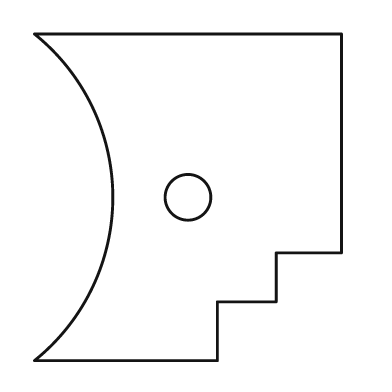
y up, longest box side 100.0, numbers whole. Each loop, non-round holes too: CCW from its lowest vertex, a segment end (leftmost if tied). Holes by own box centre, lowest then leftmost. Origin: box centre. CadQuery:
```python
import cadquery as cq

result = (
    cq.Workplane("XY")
    .moveTo(-47.0, -50.0)
    .lineTo(9.0, -50.0)
    .lineTo(9.0, -32.0)
    .lineTo(27.0, -32.0)
    .lineTo(27.0, -17.0)
    .lineTo(47.0, -17.0)
    .lineTo(47.0, 50.0)
    .lineTo(-47.0, 50.0)
    .threePointArc((-23.0, 0.0), (-47.0, -50.0))
    .close()
    .moveTo(0.0, 0.0)
    .circle(7.0)
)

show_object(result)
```